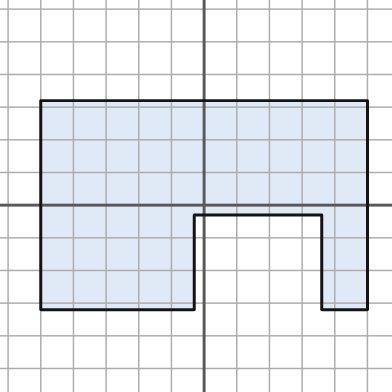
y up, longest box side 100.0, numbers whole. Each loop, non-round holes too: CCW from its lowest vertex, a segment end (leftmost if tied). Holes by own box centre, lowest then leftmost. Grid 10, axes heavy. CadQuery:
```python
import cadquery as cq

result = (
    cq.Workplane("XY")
    .moveTo(-50.0, -32.0)
    .lineTo(-3.0, -32.0)
    .lineTo(-3.0, -3.0)
    .lineTo(36.0, -3.0)
    .lineTo(36.0, -32.0)
    .lineTo(50.0, -32.0)
    .lineTo(50.0, 32.0)
    .lineTo(-50.0, 32.0)
    .close()
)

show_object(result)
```